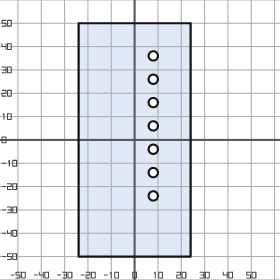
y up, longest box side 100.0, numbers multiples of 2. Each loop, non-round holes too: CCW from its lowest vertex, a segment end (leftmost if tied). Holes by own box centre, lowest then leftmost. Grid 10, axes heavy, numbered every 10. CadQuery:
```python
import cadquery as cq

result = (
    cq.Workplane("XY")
    .moveTo(-24.0, -50.0)
    .lineTo(24.0, -50.0)
    .lineTo(24.0, 50.0)
    .lineTo(-24.0, 50.0)
    .close()
    .moveTo(8.0, -24.0)
    .circle(2.0)
    .moveTo(8.0, -14.0)
    .circle(2.0)
    .moveTo(8.0, -4.0)
    .circle(2.0)
    .moveTo(8.0, 6.0)
    .circle(2.0)
    .moveTo(8.0, 16.0)
    .circle(2.0)
    .moveTo(8.0, 26.0)
    .circle(2.0)
    .moveTo(8.0, 36.0)
    .circle(2.0)
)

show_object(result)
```